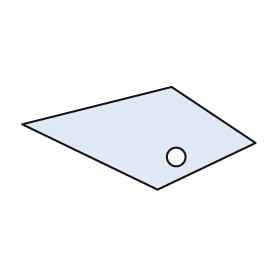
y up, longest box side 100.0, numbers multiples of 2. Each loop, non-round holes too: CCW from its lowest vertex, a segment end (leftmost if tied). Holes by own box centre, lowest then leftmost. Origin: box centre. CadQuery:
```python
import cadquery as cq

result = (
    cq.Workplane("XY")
    .moveTo(8.0, -22.0)
    .lineTo(50.0, -2.0)
    .lineTo(14.0, 22.0)
    .lineTo(-50.0, 6.0)
    .close()
    .moveTo(16.0, -8.0)
    .circle(4.0)
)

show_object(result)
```